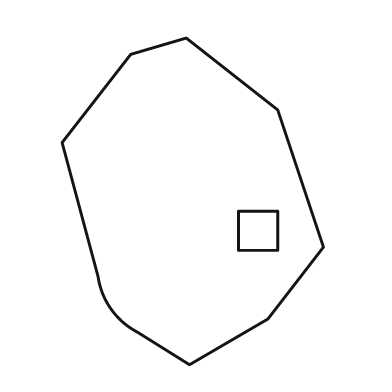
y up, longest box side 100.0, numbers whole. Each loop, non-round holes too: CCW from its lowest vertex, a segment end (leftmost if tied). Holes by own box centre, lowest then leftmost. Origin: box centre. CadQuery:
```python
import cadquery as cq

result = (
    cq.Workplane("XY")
    .moveTo(-1.0, -50.0)
    .lineTo(23.0, -36.0)
    .lineTo(40.0, -14.0)
    .lineTo(26.0, 28.0)
    .lineTo(-2.0, 50.0)
    .lineTo(-19.0, 45.0)
    .lineTo(-40.0, 18.0)
    .lineTo(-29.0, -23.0)
    .threePointArc((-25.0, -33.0), (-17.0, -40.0))
    .close()
    .moveTo(14.0, -15.0)
    .lineTo(26.0, -15.0)
    .lineTo(26.0, -3.0)
    .lineTo(14.0, -3.0)
    .close()
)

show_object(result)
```